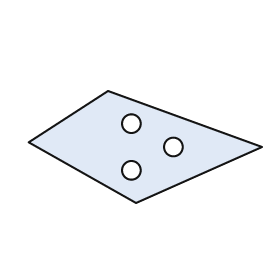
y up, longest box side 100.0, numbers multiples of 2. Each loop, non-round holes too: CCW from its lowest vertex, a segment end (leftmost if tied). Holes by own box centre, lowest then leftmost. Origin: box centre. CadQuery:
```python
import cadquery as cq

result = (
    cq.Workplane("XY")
    .moveTo(-4.0, -24.0)
    .lineTo(50.0, 0.0)
    .lineTo(-16.0, 24.0)
    .lineTo(-50.0, 2.0)
    .close()
    .moveTo(-6.0, -10.0)
    .circle(4.0)
    .moveTo(12.0, 0.0)
    .circle(4.0)
    .moveTo(-6.0, 10.0)
    .circle(4.0)
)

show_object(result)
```